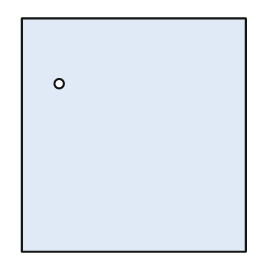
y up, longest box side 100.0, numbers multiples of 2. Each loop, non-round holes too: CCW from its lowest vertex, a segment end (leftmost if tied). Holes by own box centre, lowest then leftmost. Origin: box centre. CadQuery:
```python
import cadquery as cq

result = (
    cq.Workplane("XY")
    .moveTo(-48.0, -50.0)
    .lineTo(48.0, -50.0)
    .lineTo(48.0, 50.0)
    .lineTo(-48.0, 50.0)
    .close()
    .moveTo(-32.0, 22.0)
    .circle(2.0)
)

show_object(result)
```